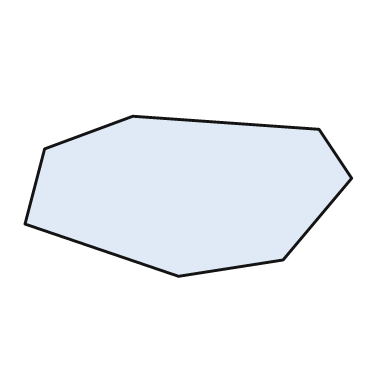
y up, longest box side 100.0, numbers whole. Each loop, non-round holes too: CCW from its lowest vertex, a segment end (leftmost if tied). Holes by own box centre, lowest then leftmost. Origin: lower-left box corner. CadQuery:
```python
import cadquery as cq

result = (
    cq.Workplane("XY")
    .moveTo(47.0, 0.0)
    .lineTo(79.0, 5.0)
    .lineTo(100.0, 30.0)
    .lineTo(90.0, 45.0)
    .lineTo(33.0, 49.0)
    .lineTo(6.0, 39.0)
    .lineTo(0.0, 16.0)
    .close()
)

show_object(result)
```